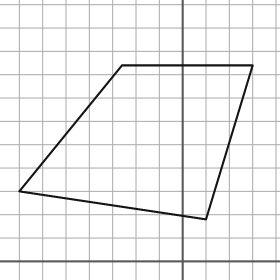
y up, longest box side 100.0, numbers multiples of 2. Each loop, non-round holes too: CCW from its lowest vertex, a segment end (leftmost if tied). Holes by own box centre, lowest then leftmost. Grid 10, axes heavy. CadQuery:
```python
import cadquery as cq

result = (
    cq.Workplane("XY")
    .moveTo(10.0, 18.0)
    .lineTo(30.0, 84.0)
    .lineTo(-26.0, 84.0)
    .lineTo(-70.0, 30.0)
    .close()
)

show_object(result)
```